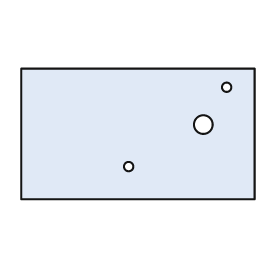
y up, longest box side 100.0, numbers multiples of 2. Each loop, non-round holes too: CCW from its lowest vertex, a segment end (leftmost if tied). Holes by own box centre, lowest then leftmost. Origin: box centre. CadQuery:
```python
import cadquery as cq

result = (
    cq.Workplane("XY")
    .moveTo(-50.0, -28.0)
    .lineTo(50.0, -28.0)
    .lineTo(50.0, 28.0)
    .lineTo(-50.0, 28.0)
    .close()
    .moveTo(-4.0, -14.0)
    .circle(2.0)
    .moveTo(28.0, 4.0)
    .circle(4.0)
    .moveTo(38.0, 20.0)
    .circle(2.0)
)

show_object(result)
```